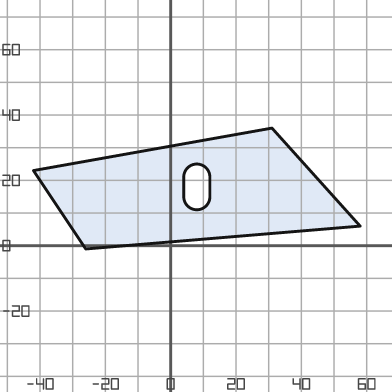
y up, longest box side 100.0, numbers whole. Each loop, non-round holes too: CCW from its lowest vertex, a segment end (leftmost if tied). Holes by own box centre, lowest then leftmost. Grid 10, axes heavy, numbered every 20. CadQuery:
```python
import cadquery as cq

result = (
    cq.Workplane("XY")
    .moveTo(-26.0, -1.0)
    .lineTo(58.0, 6.0)
    .lineTo(31.0, 36.0)
    .lineTo(-42.0, 23.0)
    .close()
    .moveTo(4.0, 15.0)
    .threePointArc((8.0, 11.0), (12.0, 15.0))
    .lineTo(12.0, 21.0)
    .threePointArc((8.0, 25.0), (4.0, 21.0))
    .close()
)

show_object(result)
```